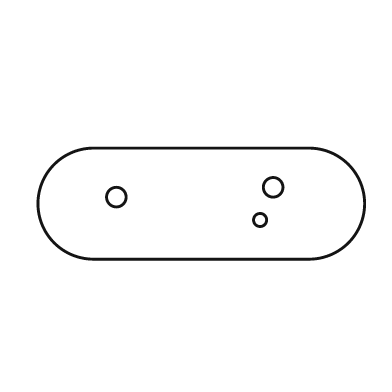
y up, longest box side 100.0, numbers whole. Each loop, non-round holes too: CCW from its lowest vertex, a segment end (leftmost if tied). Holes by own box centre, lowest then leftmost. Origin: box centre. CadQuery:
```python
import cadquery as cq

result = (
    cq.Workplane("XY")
    .moveTo(-33.0, -17.0)
    .lineTo(33.0, -17.0)
    .threePointArc((50.0, 0.0), (33.0, 17.0))
    .lineTo(-33.0, 17.0)
    .threePointArc((-50.0, 0.0), (-33.0, -17.0))
    .close()
    .moveTo(18.0, -5.0)
    .circle(2.0)
    .moveTo(-26.0, 2.0)
    .circle(3.0)
    .moveTo(22.0, 5.0)
    .circle(3.0)
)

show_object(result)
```